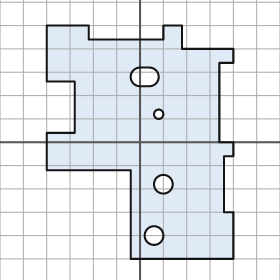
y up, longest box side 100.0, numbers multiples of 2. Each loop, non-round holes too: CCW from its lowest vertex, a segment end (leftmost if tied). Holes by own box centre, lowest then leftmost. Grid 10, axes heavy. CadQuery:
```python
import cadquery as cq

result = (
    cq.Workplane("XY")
    .moveTo(-4.0, -50.0)
    .lineTo(40.0, -50.0)
    .lineTo(40.0, -30.0)
    .lineTo(36.0, -30.0)
    .lineTo(36.0, -6.0)
    .lineTo(40.0, -6.0)
    .lineTo(40.0, 0.0)
    .lineTo(34.0, 0.0)
    .lineTo(34.0, 34.0)
    .lineTo(40.0, 34.0)
    .lineTo(40.0, 40.0)
    .lineTo(18.0, 40.0)
    .lineTo(18.0, 50.0)
    .lineTo(10.0, 50.0)
    .lineTo(10.0, 44.0)
    .lineTo(-22.0, 44.0)
    .lineTo(-22.0, 50.0)
    .lineTo(-40.0, 50.0)
    .lineTo(-40.0, 26.0)
    .lineTo(-28.0, 26.0)
    .lineTo(-28.0, 4.0)
    .lineTo(-40.0, 4.0)
    .lineTo(-40.0, -12.0)
    .lineTo(-4.0, -12.0)
    .close()
    .moveTo(6.0, -40.0)
    .circle(4.0)
    .moveTo(10.0, -18.0)
    .circle(4.0)
    .moveTo(8.0, 12.0)
    .circle(2.0)
    .moveTo(0.0, 24.0)
    .lineTo(4.0, 24.0)
    .threePointArc((8.0, 28.0), (4.0, 32.0))
    .lineTo(0.0, 32.0)
    .threePointArc((-4.0, 28.0), (0.0, 24.0))
    .close()
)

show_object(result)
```